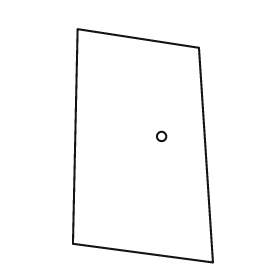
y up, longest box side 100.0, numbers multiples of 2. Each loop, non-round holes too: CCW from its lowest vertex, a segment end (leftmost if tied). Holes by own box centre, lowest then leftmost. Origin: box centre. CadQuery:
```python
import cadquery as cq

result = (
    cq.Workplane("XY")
    .moveTo(30.0, -50.0)
    .lineTo(24.0, 42.0)
    .lineTo(-28.0, 50.0)
    .lineTo(-30.0, -42.0)
    .close()
    .moveTo(8.0, 4.0)
    .circle(2.0)
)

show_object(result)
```